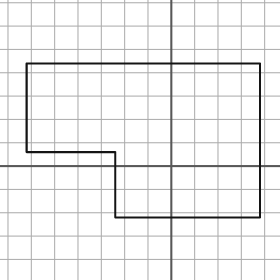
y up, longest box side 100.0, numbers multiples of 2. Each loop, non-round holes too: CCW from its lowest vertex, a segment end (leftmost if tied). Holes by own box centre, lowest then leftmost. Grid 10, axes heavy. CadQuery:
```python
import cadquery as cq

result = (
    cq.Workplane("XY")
    .moveTo(-24.0, -22.0)
    .lineTo(38.0, -22.0)
    .lineTo(38.0, 44.0)
    .lineTo(-62.0, 44.0)
    .lineTo(-62.0, 6.0)
    .lineTo(-24.0, 6.0)
    .close()
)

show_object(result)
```